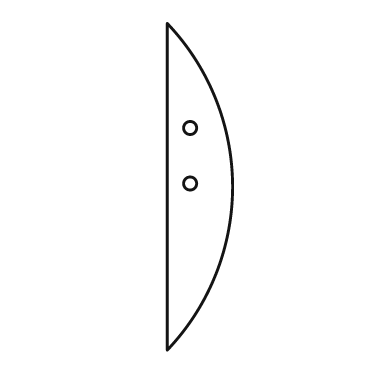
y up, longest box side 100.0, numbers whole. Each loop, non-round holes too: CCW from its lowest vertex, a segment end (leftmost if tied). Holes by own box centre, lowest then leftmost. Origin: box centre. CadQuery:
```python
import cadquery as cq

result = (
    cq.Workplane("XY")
    .moveTo(-10.0, -50.0)
    .threePointArc((10.0, 0.0), (-10.0, 50.0))
    .close()
    .moveTo(-3.0, 1.0)
    .circle(2.0)
    .moveTo(-3.0, 18.0)
    .circle(2.0)
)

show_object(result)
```